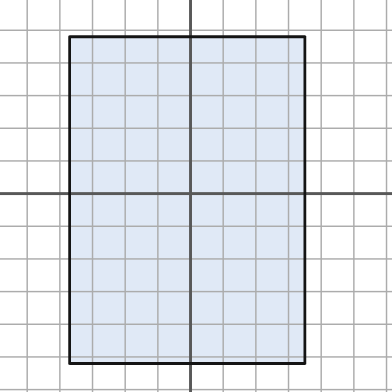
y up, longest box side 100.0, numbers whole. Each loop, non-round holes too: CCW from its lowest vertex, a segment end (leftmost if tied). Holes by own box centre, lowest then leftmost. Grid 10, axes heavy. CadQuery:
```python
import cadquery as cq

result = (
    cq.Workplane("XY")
    .moveTo(-37.0, -52.0)
    .lineTo(35.0, -52.0)
    .lineTo(35.0, 48.0)
    .lineTo(-37.0, 48.0)
    .close()
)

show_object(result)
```